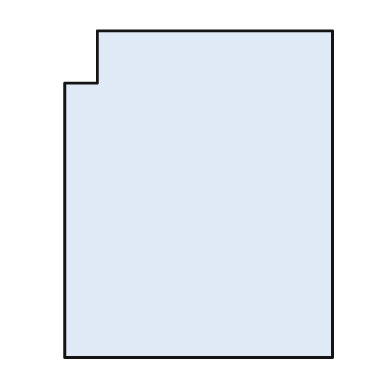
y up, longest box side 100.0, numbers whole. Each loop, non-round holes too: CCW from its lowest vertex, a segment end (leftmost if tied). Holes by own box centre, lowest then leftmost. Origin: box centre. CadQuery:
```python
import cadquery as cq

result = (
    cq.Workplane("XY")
    .moveTo(-41.0, -50.0)
    .lineTo(41.0, -50.0)
    .lineTo(41.0, 50.0)
    .lineTo(-31.0, 50.0)
    .lineTo(-31.0, 34.0)
    .lineTo(-41.0, 34.0)
    .close()
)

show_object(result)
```